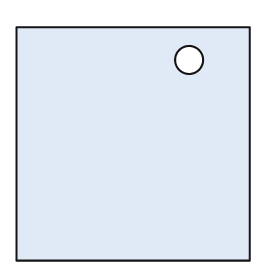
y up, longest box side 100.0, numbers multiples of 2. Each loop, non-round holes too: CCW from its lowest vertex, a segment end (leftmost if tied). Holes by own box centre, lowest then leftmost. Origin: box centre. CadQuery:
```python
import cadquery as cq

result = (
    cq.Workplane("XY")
    .moveTo(-50.0, -50.0)
    .lineTo(50.0, -50.0)
    .lineTo(50.0, 50.0)
    .lineTo(-50.0, 50.0)
    .close()
    .moveTo(24.0, 36.0)
    .circle(6.0)
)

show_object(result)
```